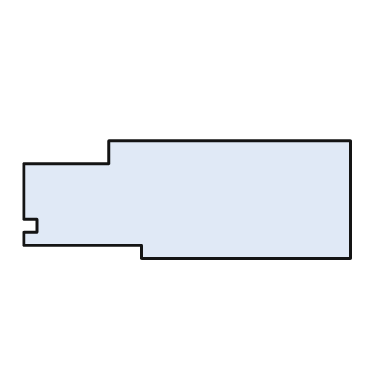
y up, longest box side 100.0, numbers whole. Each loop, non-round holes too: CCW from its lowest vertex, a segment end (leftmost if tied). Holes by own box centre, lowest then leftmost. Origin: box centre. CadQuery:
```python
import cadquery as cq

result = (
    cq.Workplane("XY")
    .moveTo(-14.0, -18.0)
    .lineTo(50.0, -18.0)
    .lineTo(50.0, 18.0)
    .lineTo(-24.0, 18.0)
    .lineTo(-24.0, 11.0)
    .lineTo(-50.0, 11.0)
    .lineTo(-50.0, -6.0)
    .lineTo(-46.0, -6.0)
    .lineTo(-46.0, -10.0)
    .lineTo(-50.0, -10.0)
    .lineTo(-50.0, -14.0)
    .lineTo(-14.0, -14.0)
    .close()
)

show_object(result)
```